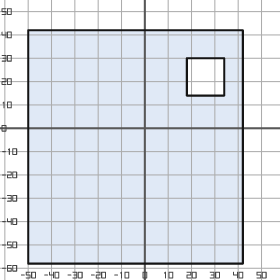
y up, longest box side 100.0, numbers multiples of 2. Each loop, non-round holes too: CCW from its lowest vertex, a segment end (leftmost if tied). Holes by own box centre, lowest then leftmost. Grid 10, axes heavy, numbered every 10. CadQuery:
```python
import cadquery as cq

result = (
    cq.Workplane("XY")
    .moveTo(-50.0, -58.0)
    .lineTo(42.0, -58.0)
    .lineTo(42.0, 42.0)
    .lineTo(-50.0, 42.0)
    .close()
    .moveTo(18.0, 14.0)
    .lineTo(34.0, 14.0)
    .lineTo(34.0, 30.0)
    .lineTo(18.0, 30.0)
    .close()
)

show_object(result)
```